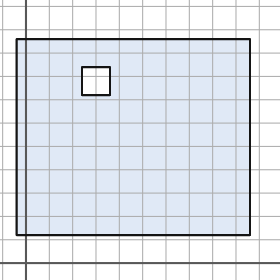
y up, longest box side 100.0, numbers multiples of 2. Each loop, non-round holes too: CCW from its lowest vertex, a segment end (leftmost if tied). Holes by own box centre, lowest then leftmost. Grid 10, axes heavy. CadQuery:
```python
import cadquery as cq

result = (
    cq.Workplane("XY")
    .moveTo(-4.0, 12.0)
    .lineTo(96.0, 12.0)
    .lineTo(96.0, 96.0)
    .lineTo(-4.0, 96.0)
    .close()
    .moveTo(24.0, 72.0)
    .lineTo(36.0, 72.0)
    .lineTo(36.0, 84.0)
    .lineTo(24.0, 84.0)
    .close()
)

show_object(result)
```